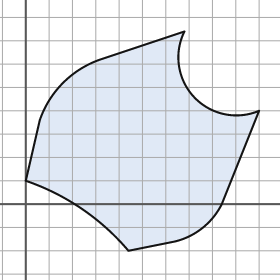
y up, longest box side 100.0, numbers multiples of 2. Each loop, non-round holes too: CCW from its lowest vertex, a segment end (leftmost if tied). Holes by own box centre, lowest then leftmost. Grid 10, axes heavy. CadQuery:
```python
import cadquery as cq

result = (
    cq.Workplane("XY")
    .moveTo(44.0, -20.0)
    .lineTo(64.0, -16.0)
    .threePointArc((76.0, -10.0), (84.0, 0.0))
    .lineTo(100.0, 40.0)
    .threePointArc((72.0, 46.0), (68.0, 74.0))
    .lineTo(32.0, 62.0)
    .threePointArc((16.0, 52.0), (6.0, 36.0))
    .lineTo(0.0, 10.0)
    .threePointArc((24.0, -2.0), (44.0, -20.0))
    .close()
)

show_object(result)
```